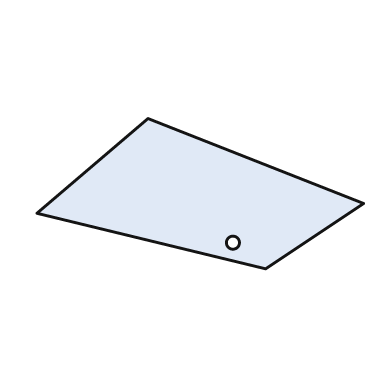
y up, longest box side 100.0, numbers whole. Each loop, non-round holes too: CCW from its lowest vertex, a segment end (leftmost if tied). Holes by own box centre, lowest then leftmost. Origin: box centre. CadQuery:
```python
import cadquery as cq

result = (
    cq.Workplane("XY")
    .moveTo(20.0, -23.0)
    .lineTo(50.0, -3.0)
    .lineTo(-16.0, 23.0)
    .lineTo(-50.0, -6.0)
    .close()
    .moveTo(10.0, -15.0)
    .circle(2.0)
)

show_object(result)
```